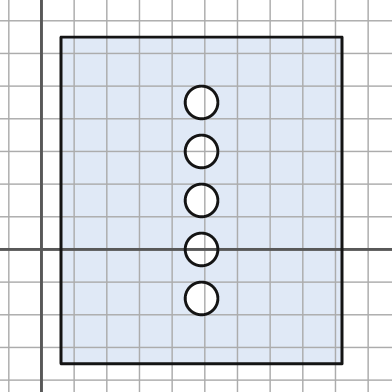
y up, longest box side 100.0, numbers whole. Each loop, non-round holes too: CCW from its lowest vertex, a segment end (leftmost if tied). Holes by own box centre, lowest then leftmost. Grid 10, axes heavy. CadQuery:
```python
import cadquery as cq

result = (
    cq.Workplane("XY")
    .moveTo(6.0, -35.0)
    .lineTo(92.0, -35.0)
    .lineTo(92.0, 65.0)
    .lineTo(6.0, 65.0)
    .close()
    .moveTo(49.0, -15.0)
    .circle(5.0)
    .moveTo(49.0, 0.0)
    .circle(5.0)
    .moveTo(49.0, 15.0)
    .circle(5.0)
    .moveTo(49.0, 30.0)
    .circle(5.0)
    .moveTo(49.0, 45.0)
    .circle(5.0)
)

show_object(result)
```